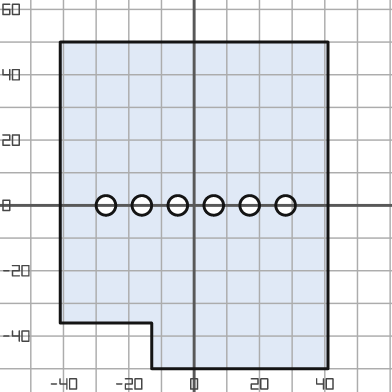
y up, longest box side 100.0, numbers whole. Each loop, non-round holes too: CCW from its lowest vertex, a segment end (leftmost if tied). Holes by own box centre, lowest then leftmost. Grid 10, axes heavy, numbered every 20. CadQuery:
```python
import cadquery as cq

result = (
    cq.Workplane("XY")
    .moveTo(-13.0, -50.0)
    .lineTo(41.0, -50.0)
    .lineTo(41.0, 50.0)
    .lineTo(-41.0, 50.0)
    .lineTo(-41.0, -36.0)
    .lineTo(-13.0, -36.0)
    .close()
    .moveTo(-27.0, 0.0)
    .circle(3.0)
    .moveTo(-16.0, 0.0)
    .circle(3.0)
    .moveTo(-5.0, 0.0)
    .circle(3.0)
    .moveTo(6.0, 0.0)
    .circle(3.0)
    .moveTo(17.0, 0.0)
    .circle(3.0)
    .moveTo(28.0, 0.0)
    .circle(3.0)
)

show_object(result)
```